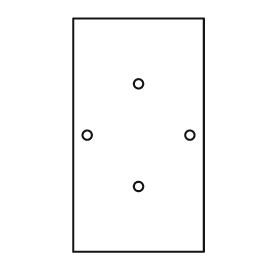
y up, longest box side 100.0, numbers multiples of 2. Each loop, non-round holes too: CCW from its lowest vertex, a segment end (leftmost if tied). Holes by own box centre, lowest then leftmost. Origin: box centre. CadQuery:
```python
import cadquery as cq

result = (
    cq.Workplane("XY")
    .moveTo(-28.0, -50.0)
    .lineTo(28.0, -50.0)
    .lineTo(28.0, 50.0)
    .lineTo(-28.0, 50.0)
    .close()
    .moveTo(0.0, -22.0)
    .circle(2.0)
    .moveTo(-22.0, 0.0)
    .circle(2.0)
    .moveTo(22.0, 0.0)
    .circle(2.0)
    .moveTo(0.0, 22.0)
    .circle(2.0)
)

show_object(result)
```